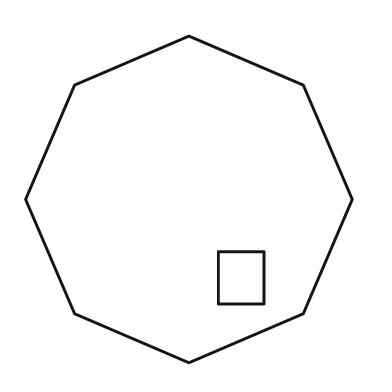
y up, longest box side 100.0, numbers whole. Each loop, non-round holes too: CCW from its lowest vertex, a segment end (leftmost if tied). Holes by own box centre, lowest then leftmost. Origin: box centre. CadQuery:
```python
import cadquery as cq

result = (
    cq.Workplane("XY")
    .moveTo(0.0, -50.0)
    .lineTo(35.0, -35.0)
    .lineTo(50.0, 0.0)
    .lineTo(35.0, 35.0)
    .lineTo(0.0, 50.0)
    .lineTo(-35.0, 35.0)
    .lineTo(-50.0, 0.0)
    .lineTo(-35.0, -35.0)
    .close()
    .moveTo(9.0, -32.0)
    .lineTo(23.0, -32.0)
    .lineTo(23.0, -16.0)
    .lineTo(9.0, -16.0)
    .close()
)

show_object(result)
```